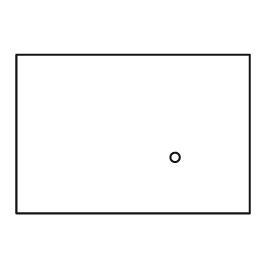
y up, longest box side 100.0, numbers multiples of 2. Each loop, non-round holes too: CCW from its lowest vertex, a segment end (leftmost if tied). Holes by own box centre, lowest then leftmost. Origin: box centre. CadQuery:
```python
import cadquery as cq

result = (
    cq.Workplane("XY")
    .moveTo(-50.0, -34.0)
    .lineTo(50.0, -34.0)
    .lineTo(50.0, 34.0)
    .lineTo(-50.0, 34.0)
    .close()
    .moveTo(18.0, -10.0)
    .circle(2.0)
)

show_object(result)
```